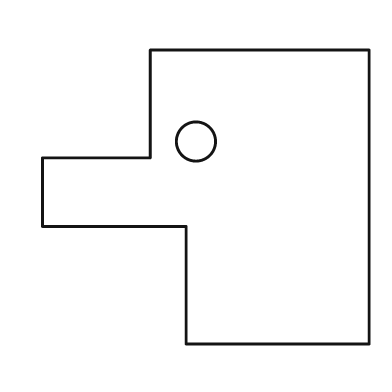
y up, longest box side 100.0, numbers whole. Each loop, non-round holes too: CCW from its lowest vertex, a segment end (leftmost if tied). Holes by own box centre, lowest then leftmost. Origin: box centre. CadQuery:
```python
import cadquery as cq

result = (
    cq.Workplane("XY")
    .moveTo(-6.0, -45.0)
    .lineTo(50.0, -45.0)
    .lineTo(50.0, 45.0)
    .lineTo(-17.0, 45.0)
    .lineTo(-17.0, 12.0)
    .lineTo(-50.0, 12.0)
    .lineTo(-50.0, -9.0)
    .lineTo(-6.0, -9.0)
    .close()
    .moveTo(-3.0, 17.0)
    .circle(6.0)
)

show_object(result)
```